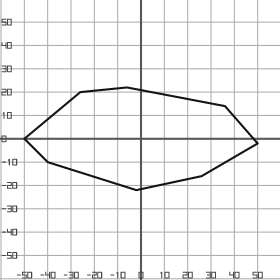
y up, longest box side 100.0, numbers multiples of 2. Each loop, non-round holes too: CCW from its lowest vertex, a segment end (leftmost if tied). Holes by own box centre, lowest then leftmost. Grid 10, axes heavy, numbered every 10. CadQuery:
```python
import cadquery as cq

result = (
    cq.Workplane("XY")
    .moveTo(-2.0, -22.0)
    .lineTo(26.0, -16.0)
    .lineTo(50.0, -2.0)
    .lineTo(36.0, 14.0)
    .lineTo(-6.0, 22.0)
    .lineTo(-26.0, 20.0)
    .lineTo(-50.0, 0.0)
    .lineTo(-40.0, -10.0)
    .close()
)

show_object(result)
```